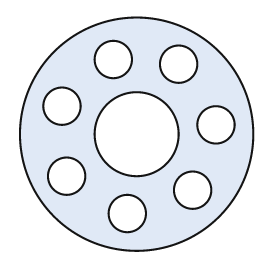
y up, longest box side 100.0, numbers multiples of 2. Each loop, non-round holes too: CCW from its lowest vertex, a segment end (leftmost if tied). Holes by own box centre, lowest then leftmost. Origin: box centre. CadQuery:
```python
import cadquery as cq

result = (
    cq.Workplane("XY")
    .moveTo(0.0, 0.0)
    .circle(50.0)
    .moveTo(-4.0, -34.0)
    .circle(8.0)
    .moveTo(24.0, -24.0)
    .circle(8.0)
    .moveTo(-30.0, -18.0)
    .circle(8.0)
    .moveTo(0.0, 0.0)
    .circle(18.0)
    .moveTo(34.0, 4.0)
    .circle(8.0)
    .moveTo(-32.0, 12.0)
    .circle(8.0)
    .moveTo(18.0, 30.0)
    .circle(8.0)
    .moveTo(-10.0, 32.0)
    .circle(8.0)
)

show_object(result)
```